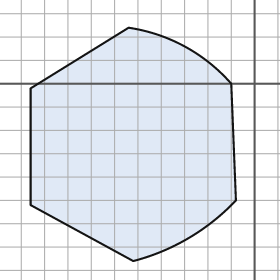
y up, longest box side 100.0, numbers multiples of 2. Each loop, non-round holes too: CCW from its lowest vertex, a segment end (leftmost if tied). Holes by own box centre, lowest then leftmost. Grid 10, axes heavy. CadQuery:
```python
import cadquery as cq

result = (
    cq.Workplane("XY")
    .moveTo(-52.0, -76.0)
    .threePointArc((-28.0, -66.0), (-8.0, -50.0))
    .lineTo(-10.0, 0.0)
    .threePointArc((-30.0, 16.0), (-54.0, 24.0))
    .lineTo(-96.0, -2.0)
    .lineTo(-96.0, -52.0)
    .close()
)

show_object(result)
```